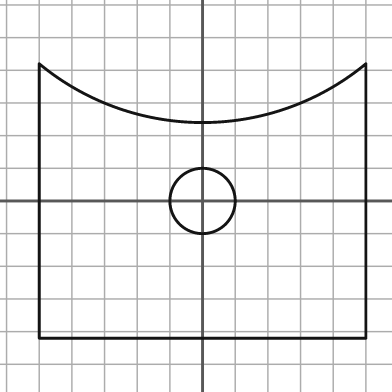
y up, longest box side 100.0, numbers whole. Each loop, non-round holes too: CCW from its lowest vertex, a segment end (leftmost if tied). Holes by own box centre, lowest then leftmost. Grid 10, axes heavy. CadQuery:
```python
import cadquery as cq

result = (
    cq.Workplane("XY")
    .moveTo(-50.0, -42.0)
    .lineTo(50.0, -42.0)
    .lineTo(50.0, 42.0)
    .threePointArc((0.0, 24.0), (-50.0, 42.0))
    .close()
    .moveTo(0.0, 0.0)
    .circle(10.0)
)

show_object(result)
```